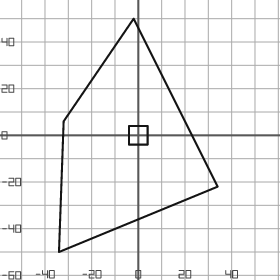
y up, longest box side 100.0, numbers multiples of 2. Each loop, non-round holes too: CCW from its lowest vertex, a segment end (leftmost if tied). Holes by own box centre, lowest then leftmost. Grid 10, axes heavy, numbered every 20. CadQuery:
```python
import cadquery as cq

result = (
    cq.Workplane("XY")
    .moveTo(-34.0, -50.0)
    .lineTo(34.0, -22.0)
    .lineTo(-2.0, 50.0)
    .lineTo(-32.0, 6.0)
    .close()
    .moveTo(-4.0, -4.0)
    .lineTo(4.0, -4.0)
    .lineTo(4.0, 4.0)
    .lineTo(-4.0, 4.0)
    .close()
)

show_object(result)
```